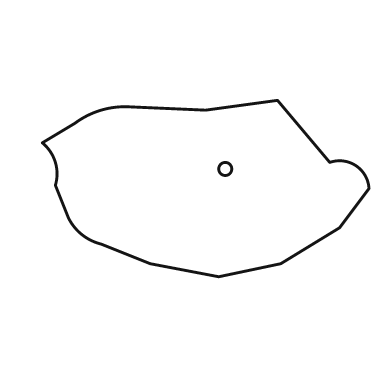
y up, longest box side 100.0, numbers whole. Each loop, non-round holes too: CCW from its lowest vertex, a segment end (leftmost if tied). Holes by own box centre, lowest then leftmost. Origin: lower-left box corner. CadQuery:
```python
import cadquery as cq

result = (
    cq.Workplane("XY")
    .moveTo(54.0, 0.0)
    .lineTo(73.0, 4.0)
    .lineTo(91.0, 15.0)
    .lineTo(100.0, 27.0)
    .threePointArc((96.0, 34.0), (88.0, 35.0))
    .lineTo(72.0, 54.0)
    .lineTo(50.0, 51.0)
    .lineTo(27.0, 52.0)
    .threePointArc((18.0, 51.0), (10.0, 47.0))
    .lineTo(0.0, 41.0)
    .threePointArc((4.0, 35.0), (4.0, 28.0))
    .lineTo(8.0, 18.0)
    .threePointArc((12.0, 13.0), (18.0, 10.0))
    .lineTo(33.0, 4.0)
    .close()
    .moveTo(56.0, 33.0)
    .circle(2.0)
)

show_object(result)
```